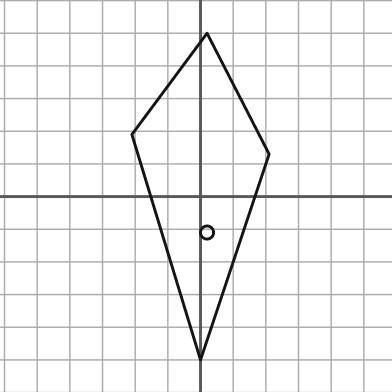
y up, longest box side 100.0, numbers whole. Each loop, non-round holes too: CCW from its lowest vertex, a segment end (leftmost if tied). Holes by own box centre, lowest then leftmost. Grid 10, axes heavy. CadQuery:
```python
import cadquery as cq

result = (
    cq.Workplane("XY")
    .moveTo(0.0, -50.0)
    .lineTo(21.0, 13.0)
    .lineTo(2.0, 50.0)
    .lineTo(-21.0, 19.0)
    .close()
    .moveTo(2.0, -11.0)
    .circle(2.0)
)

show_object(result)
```